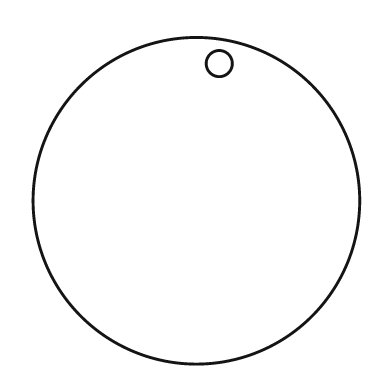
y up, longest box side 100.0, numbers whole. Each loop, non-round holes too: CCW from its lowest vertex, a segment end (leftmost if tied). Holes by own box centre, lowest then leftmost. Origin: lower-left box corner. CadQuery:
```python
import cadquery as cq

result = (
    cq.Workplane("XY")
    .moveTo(50.0, 50.0)
    .circle(50.0)
    .moveTo(57.0, 92.0)
    .circle(4.0)
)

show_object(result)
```